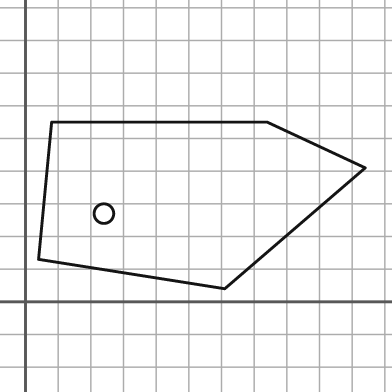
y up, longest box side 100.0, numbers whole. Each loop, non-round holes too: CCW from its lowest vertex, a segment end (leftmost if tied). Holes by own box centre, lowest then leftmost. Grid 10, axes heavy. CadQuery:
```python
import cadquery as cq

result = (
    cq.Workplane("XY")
    .moveTo(61.0, 4.0)
    .lineTo(104.0, 41.0)
    .lineTo(74.0, 55.0)
    .lineTo(8.0, 55.0)
    .lineTo(4.0, 13.0)
    .close()
    .moveTo(24.0, 27.0)
    .circle(3.0)
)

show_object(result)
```